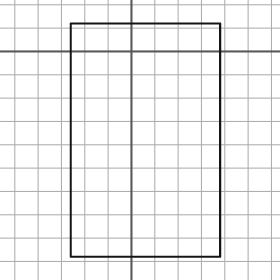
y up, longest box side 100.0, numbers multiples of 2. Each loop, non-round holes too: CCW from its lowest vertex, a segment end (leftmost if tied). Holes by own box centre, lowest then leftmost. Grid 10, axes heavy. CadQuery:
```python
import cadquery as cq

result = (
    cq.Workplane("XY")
    .moveTo(-26.0, -88.0)
    .lineTo(38.0, -88.0)
    .lineTo(38.0, 12.0)
    .lineTo(-26.0, 12.0)
    .close()
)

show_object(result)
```